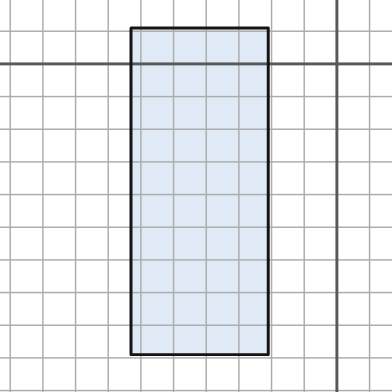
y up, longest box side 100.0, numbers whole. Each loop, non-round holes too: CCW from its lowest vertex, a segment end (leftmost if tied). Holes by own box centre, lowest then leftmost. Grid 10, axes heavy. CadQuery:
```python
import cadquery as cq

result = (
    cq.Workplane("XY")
    .moveTo(-63.0, -89.0)
    .lineTo(-21.0, -89.0)
    .lineTo(-21.0, 11.0)
    .lineTo(-63.0, 11.0)
    .close()
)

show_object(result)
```